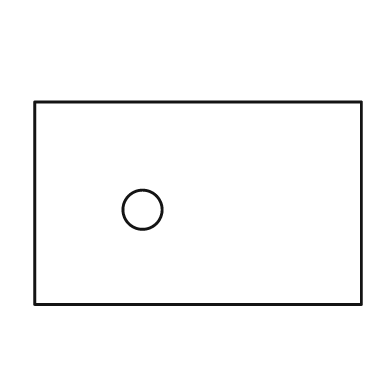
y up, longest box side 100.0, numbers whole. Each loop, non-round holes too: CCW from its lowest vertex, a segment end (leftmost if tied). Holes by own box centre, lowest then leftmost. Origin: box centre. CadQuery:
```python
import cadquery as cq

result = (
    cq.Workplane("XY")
    .moveTo(-50.0, -31.0)
    .lineTo(50.0, -31.0)
    .lineTo(50.0, 31.0)
    .lineTo(-50.0, 31.0)
    .close()
    .moveTo(-17.0, -2.0)
    .circle(6.0)
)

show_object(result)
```